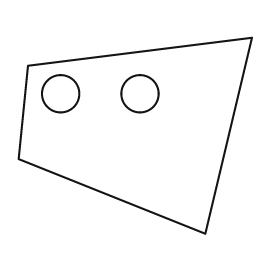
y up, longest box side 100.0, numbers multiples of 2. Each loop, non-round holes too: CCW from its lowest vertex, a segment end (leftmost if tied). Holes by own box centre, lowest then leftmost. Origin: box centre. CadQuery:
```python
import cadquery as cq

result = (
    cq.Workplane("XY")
    .moveTo(30.0, -42.0)
    .lineTo(50.0, 42.0)
    .lineTo(-46.0, 30.0)
    .lineTo(-50.0, -10.0)
    .close()
    .moveTo(-32.0, 18.0)
    .circle(8.0)
    .moveTo(2.0, 18.0)
    .circle(8.0)
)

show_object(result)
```